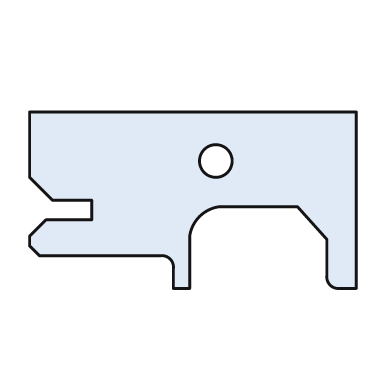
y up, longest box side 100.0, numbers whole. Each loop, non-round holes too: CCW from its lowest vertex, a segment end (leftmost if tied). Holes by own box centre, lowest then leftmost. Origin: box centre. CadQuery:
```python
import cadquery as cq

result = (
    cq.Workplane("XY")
    .moveTo(-6.0, -27.0)
    .lineTo(-1.0, -27.0)
    .lineTo(-1.0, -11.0)
    .threePointArc((2.0, -5.0), (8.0, -2.0))
    .lineTo(32.0, -2.0)
    .lineTo(41.0, -12.0)
    .lineTo(41.0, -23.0)
    .threePointArc((42.0, -26.0), (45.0, -27.0))
    .lineTo(50.0, -27.0)
    .lineTo(50.0, 27.0)
    .lineTo(-50.0, 27.0)
    .lineTo(-50.0, 7.0)
    .lineTo(-43.0, 0.0)
    .lineTo(-31.0, 0.0)
    .lineTo(-31.0, -6.0)
    .lineTo(-45.0, -6.0)
    .lineTo(-50.0, -11.0)
    .lineTo(-50.0, -14.0)
    .lineTo(-47.0, -17.0)
    .lineTo(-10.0, -17.0)
    .threePointArc((-7.0, -18.0), (-6.0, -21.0))
    .close()
    .moveTo(7.0, 12.0)
    .circle(5.0)
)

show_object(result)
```